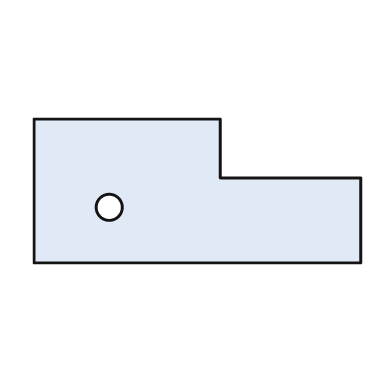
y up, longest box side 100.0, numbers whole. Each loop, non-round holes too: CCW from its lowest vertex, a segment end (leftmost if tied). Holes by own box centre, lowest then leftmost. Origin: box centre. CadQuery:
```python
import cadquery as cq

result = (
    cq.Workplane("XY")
    .moveTo(-50.0, -22.0)
    .lineTo(50.0, -22.0)
    .lineTo(50.0, 4.0)
    .lineTo(7.0, 4.0)
    .lineTo(7.0, 22.0)
    .lineTo(-50.0, 22.0)
    .close()
    .moveTo(-27.0, -5.0)
    .circle(4.0)
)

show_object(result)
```